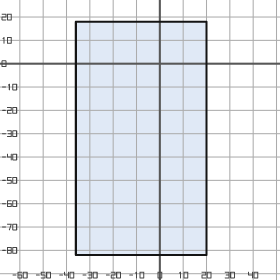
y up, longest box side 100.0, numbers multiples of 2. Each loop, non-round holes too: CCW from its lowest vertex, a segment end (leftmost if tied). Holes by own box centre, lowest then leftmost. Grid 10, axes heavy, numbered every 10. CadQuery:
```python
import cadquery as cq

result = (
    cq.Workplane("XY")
    .moveTo(-36.0, -82.0)
    .lineTo(20.0, -82.0)
    .lineTo(20.0, 18.0)
    .lineTo(-36.0, 18.0)
    .close()
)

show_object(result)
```